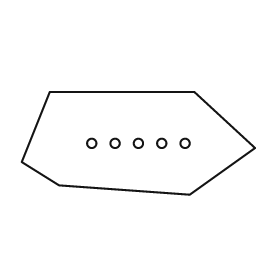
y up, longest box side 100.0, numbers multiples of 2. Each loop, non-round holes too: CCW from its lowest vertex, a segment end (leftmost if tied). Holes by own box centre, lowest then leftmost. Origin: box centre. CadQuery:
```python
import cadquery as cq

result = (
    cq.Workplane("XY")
    .moveTo(22.0, -22.0)
    .lineTo(50.0, -2.0)
    .lineTo(24.0, 22.0)
    .lineTo(-38.0, 22.0)
    .lineTo(-50.0, -8.0)
    .lineTo(-34.0, -18.0)
    .close()
    .moveTo(-20.0, 0.0)
    .circle(2.0)
    .moveTo(-10.0, 0.0)
    .circle(2.0)
    .moveTo(0.0, 0.0)
    .circle(2.0)
    .moveTo(10.0, 0.0)
    .circle(2.0)
    .moveTo(20.0, 0.0)
    .circle(2.0)
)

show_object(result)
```